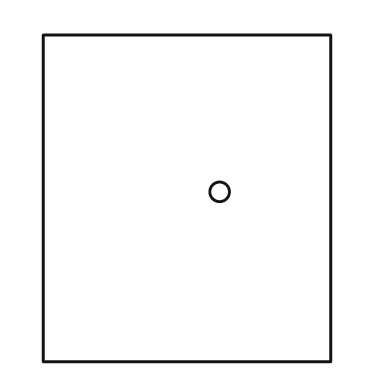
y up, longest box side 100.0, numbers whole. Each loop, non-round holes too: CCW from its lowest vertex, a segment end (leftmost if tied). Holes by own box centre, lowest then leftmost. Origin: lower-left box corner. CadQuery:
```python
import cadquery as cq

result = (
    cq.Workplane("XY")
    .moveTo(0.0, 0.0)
    .lineTo(88.0, 0.0)
    .lineTo(88.0, 100.0)
    .lineTo(0.0, 100.0)
    .close()
    .moveTo(54.0, 52.0)
    .circle(3.0)
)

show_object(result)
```